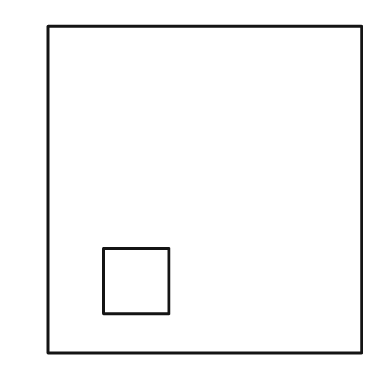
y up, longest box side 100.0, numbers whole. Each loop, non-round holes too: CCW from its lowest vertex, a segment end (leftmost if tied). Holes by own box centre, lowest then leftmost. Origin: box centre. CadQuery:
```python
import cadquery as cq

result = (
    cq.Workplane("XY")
    .moveTo(-48.0, -50.0)
    .lineTo(48.0, -50.0)
    .lineTo(48.0, 50.0)
    .lineTo(-48.0, 50.0)
    .close()
    .moveTo(-31.0, -38.0)
    .lineTo(-11.0, -38.0)
    .lineTo(-11.0, -18.0)
    .lineTo(-31.0, -18.0)
    .close()
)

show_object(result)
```